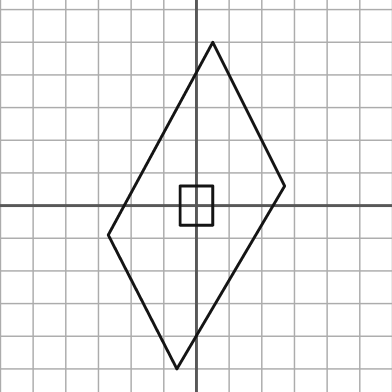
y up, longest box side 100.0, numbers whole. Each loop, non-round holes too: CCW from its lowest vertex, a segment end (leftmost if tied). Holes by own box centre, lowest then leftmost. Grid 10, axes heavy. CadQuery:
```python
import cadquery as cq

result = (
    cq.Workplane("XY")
    .moveTo(-6.0, -50.0)
    .lineTo(27.0, 6.0)
    .lineTo(5.0, 50.0)
    .lineTo(-27.0, -9.0)
    .close()
    .moveTo(-5.0, -6.0)
    .lineTo(5.0, -6.0)
    .lineTo(5.0, 6.0)
    .lineTo(-5.0, 6.0)
    .close()
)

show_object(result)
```